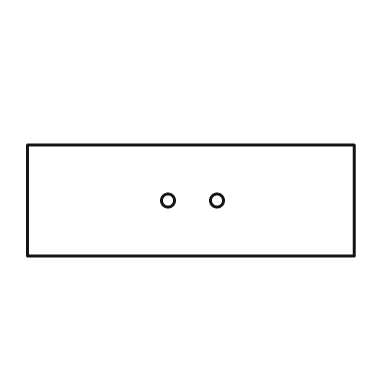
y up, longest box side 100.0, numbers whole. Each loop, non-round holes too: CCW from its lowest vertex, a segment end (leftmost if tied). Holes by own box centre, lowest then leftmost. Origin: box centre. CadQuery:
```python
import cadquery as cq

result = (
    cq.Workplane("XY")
    .moveTo(-50.0, -17.0)
    .lineTo(50.0, -17.0)
    .lineTo(50.0, 17.0)
    .lineTo(-50.0, 17.0)
    .close()
    .moveTo(-7.0, 0.0)
    .circle(2.0)
    .moveTo(8.0, 0.0)
    .circle(2.0)
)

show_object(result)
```